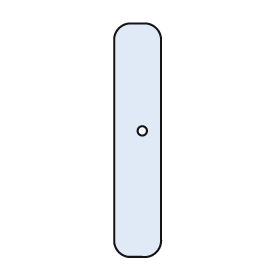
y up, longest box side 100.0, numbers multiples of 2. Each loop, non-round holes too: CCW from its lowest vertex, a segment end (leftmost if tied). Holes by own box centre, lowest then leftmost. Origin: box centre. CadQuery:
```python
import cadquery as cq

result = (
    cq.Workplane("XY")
    .moveTo(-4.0, -50.0)
    .lineTo(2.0, -50.0)
    .threePointArc((8.0, -48.0), (10.0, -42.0))
    .lineTo(10.0, 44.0)
    .threePointArc((8.0, 48.0), (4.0, 50.0))
    .lineTo(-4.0, 50.0)
    .threePointArc((-8.0, 48.0), (-10.0, 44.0))
    .lineTo(-10.0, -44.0)
    .threePointArc((-8.0, -48.0), (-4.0, -50.0))
    .close()
    .moveTo(2.0, 4.0)
    .circle(2.0)
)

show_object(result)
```